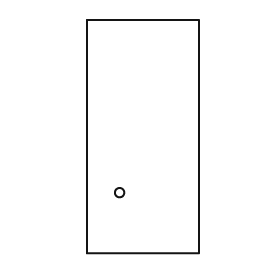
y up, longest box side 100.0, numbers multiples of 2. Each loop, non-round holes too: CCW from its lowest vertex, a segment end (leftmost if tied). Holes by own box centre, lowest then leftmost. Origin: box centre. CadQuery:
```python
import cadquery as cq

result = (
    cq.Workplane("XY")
    .moveTo(-24.0, -50.0)
    .lineTo(24.0, -50.0)
    .lineTo(24.0, 50.0)
    .lineTo(-24.0, 50.0)
    .close()
    .moveTo(-10.0, -24.0)
    .circle(2.0)
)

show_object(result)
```